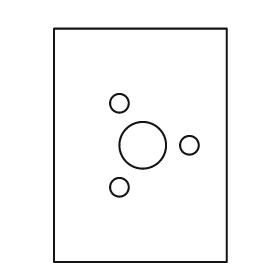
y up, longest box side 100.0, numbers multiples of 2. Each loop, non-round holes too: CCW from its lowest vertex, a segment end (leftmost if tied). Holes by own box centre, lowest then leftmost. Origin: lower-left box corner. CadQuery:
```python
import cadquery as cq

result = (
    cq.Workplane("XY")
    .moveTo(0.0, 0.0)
    .lineTo(74.0, 0.0)
    .lineTo(74.0, 100.0)
    .lineTo(0.0, 100.0)
    .close()
    .moveTo(28.0, 32.0)
    .circle(4.0)
    .moveTo(38.0, 50.0)
    .circle(10.0)
    .moveTo(58.0, 50.0)
    .circle(4.0)
    .moveTo(28.0, 68.0)
    .circle(4.0)
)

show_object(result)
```